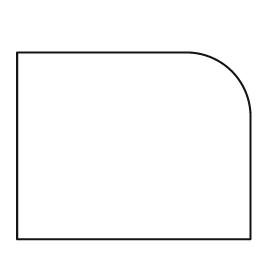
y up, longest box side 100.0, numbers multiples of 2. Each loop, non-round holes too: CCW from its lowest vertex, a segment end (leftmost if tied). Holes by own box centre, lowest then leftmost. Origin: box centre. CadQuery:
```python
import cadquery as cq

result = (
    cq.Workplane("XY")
    .moveTo(-50.0, -40.0)
    .lineTo(50.0, -40.0)
    .lineTo(50.0, 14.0)
    .threePointArc((42.0, 32.0), (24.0, 40.0))
    .lineTo(-50.0, 40.0)
    .close()
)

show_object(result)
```